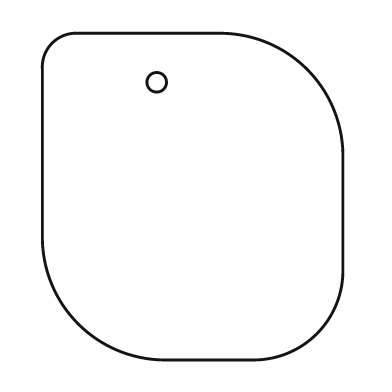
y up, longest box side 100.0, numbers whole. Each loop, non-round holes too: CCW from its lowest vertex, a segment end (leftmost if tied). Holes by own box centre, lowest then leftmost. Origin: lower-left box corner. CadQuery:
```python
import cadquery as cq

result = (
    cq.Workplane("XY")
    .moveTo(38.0, 0.0)
    .lineTo(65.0, 0.0)
    .threePointArc((84.0, 8.0), (92.0, 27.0))
    .lineTo(92.0, 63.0)
    .threePointArc((81.0, 89.0), (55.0, 100.0))
    .lineTo(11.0, 100.0)
    .threePointArc((3.0, 97.0), (0.0, 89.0))
    .lineTo(0.0, 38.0)
    .threePointArc((11.0, 11.0), (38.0, 0.0))
    .close()
    .moveTo(35.0, 85.0)
    .circle(3.0)
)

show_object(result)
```